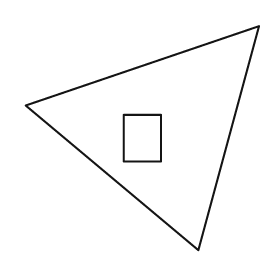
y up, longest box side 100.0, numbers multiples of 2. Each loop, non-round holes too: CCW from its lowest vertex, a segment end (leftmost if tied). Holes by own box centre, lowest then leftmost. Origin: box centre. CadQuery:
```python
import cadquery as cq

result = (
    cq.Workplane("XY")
    .moveTo(24.0, -48.0)
    .lineTo(50.0, 48.0)
    .lineTo(-50.0, 14.0)
    .close()
    .moveTo(-8.0, -10.0)
    .lineTo(8.0, -10.0)
    .lineTo(8.0, 10.0)
    .lineTo(-8.0, 10.0)
    .close()
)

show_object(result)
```